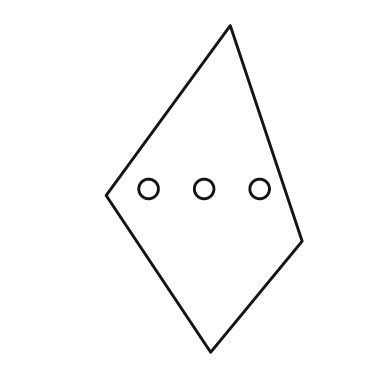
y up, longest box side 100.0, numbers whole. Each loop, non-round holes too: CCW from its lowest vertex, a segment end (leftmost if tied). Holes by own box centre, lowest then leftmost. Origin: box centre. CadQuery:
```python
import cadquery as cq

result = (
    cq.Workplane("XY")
    .moveTo(2.0, -50.0)
    .lineTo(30.0, -16.0)
    .lineTo(8.0, 50.0)
    .lineTo(-30.0, -2.0)
    .close()
    .moveTo(-17.0, 0.0)
    .circle(3.0)
    .moveTo(0.0, 0.0)
    .circle(3.0)
    .moveTo(17.0, 0.0)
    .circle(3.0)
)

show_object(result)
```